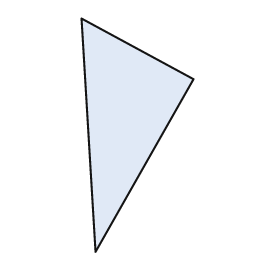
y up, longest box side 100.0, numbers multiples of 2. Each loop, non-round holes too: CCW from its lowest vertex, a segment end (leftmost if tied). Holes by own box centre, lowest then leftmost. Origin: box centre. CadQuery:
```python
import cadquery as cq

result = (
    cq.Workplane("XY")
    .moveTo(-18.0, -50.0)
    .lineTo(24.0, 24.0)
    .lineTo(-24.0, 50.0)
    .close()
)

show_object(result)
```